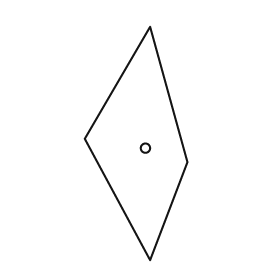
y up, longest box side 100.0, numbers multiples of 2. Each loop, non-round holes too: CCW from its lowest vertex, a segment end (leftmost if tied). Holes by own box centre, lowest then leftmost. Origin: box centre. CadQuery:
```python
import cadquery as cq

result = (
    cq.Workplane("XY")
    .moveTo(6.0, -50.0)
    .lineTo(22.0, -8.0)
    .lineTo(6.0, 50.0)
    .lineTo(-22.0, 2.0)
    .close()
    .moveTo(4.0, -2.0)
    .circle(2.0)
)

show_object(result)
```